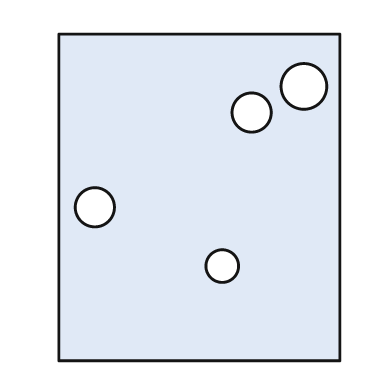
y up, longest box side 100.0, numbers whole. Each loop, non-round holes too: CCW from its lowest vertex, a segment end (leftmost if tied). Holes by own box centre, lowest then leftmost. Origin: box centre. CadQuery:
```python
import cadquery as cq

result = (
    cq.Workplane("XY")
    .moveTo(-43.0, -50.0)
    .lineTo(43.0, -50.0)
    .lineTo(43.0, 50.0)
    .lineTo(-43.0, 50.0)
    .close()
    .moveTo(7.0, -21.0)
    .circle(5.0)
    .moveTo(-32.0, -3.0)
    .circle(6.0)
    .moveTo(16.0, 26.0)
    .circle(6.0)
    .moveTo(32.0, 34.0)
    .circle(7.0)
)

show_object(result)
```